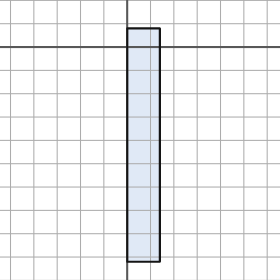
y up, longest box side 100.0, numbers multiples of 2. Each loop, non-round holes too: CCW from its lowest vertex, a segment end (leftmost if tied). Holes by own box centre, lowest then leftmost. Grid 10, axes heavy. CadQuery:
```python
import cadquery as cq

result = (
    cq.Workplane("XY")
    .moveTo(0.0, -92.0)
    .lineTo(14.0, -92.0)
    .lineTo(14.0, 8.0)
    .lineTo(0.0, 8.0)
    .close()
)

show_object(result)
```